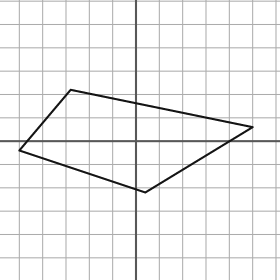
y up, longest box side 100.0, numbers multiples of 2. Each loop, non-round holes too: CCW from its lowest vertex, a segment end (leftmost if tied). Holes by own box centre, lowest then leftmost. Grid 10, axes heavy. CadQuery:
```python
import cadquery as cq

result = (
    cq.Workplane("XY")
    .moveTo(4.0, -22.0)
    .lineTo(50.0, 6.0)
    .lineTo(-28.0, 22.0)
    .lineTo(-50.0, -4.0)
    .close()
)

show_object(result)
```